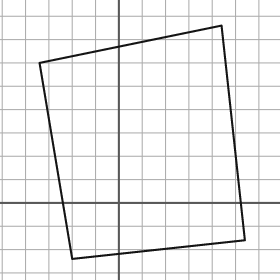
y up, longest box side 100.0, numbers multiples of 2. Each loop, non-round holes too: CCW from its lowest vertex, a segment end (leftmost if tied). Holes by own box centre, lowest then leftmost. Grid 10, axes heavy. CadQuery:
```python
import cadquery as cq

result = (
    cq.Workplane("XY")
    .moveTo(-20.0, -24.0)
    .lineTo(54.0, -16.0)
    .lineTo(44.0, 76.0)
    .lineTo(-34.0, 60.0)
    .close()
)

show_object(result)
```